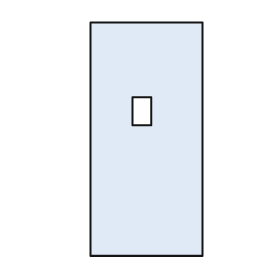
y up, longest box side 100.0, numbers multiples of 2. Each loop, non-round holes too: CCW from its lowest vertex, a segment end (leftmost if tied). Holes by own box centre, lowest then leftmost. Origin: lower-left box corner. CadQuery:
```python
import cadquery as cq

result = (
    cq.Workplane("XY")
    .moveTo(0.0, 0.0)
    .lineTo(48.0, 0.0)
    .lineTo(48.0, 100.0)
    .lineTo(0.0, 100.0)
    .close()
    .moveTo(18.0, 56.0)
    .lineTo(26.0, 56.0)
    .lineTo(26.0, 68.0)
    .lineTo(18.0, 68.0)
    .close()
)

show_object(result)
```